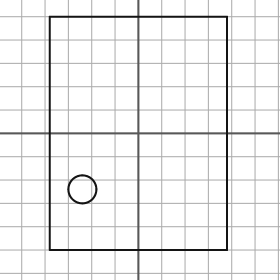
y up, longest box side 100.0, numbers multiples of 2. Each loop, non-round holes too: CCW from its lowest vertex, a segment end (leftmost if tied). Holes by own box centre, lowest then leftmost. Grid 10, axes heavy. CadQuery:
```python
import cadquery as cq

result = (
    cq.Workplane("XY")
    .moveTo(-38.0, -50.0)
    .lineTo(38.0, -50.0)
    .lineTo(38.0, 50.0)
    .lineTo(-38.0, 50.0)
    .close()
    .moveTo(-24.0, -24.0)
    .circle(6.0)
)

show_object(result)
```